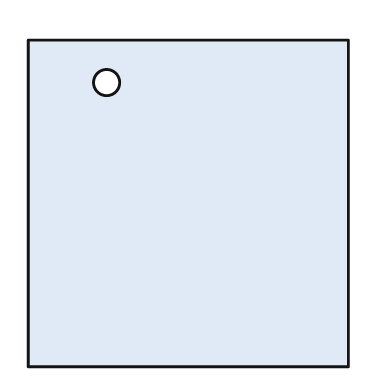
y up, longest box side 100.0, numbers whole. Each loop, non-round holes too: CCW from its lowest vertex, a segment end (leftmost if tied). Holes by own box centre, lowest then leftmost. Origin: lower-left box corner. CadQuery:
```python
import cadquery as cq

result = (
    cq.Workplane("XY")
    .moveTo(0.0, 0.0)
    .lineTo(98.0, 0.0)
    .lineTo(98.0, 100.0)
    .lineTo(0.0, 100.0)
    .close()
    .moveTo(24.0, 87.0)
    .circle(4.0)
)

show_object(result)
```